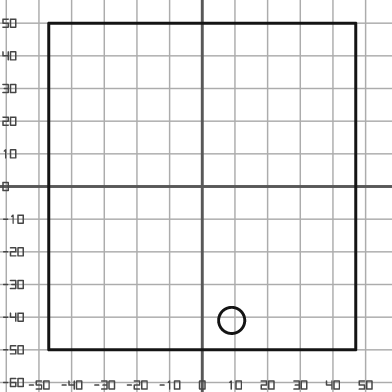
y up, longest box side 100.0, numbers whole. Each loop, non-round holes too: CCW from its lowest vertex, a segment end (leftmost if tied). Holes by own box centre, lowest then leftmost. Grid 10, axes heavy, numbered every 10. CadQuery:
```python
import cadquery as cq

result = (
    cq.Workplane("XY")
    .moveTo(-47.0, -50.0)
    .lineTo(47.0, -50.0)
    .lineTo(47.0, 50.0)
    .lineTo(-47.0, 50.0)
    .close()
    .moveTo(9.0, -41.0)
    .circle(4.0)
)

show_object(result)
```